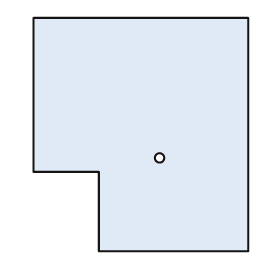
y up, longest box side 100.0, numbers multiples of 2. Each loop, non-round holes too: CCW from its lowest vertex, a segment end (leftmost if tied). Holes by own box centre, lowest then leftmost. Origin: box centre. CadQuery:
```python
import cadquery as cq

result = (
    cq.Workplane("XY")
    .moveTo(-18.0, -50.0)
    .lineTo(46.0, -50.0)
    .lineTo(46.0, 50.0)
    .lineTo(-46.0, 50.0)
    .lineTo(-46.0, -16.0)
    .lineTo(-18.0, -16.0)
    .close()
    .moveTo(8.0, -10.0)
    .circle(2.0)
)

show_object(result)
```